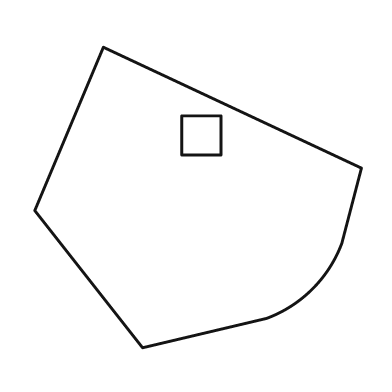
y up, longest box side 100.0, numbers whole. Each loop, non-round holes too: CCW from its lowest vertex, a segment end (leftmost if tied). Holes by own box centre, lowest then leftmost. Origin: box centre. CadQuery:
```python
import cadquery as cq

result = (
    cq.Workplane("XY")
    .moveTo(-17.0, -46.0)
    .lineTo(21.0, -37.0)
    .threePointArc((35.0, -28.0), (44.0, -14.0))
    .lineTo(50.0, 9.0)
    .lineTo(-29.0, 46.0)
    .lineTo(-50.0, -4.0)
    .close()
    .moveTo(-5.0, 13.0)
    .lineTo(7.0, 13.0)
    .lineTo(7.0, 25.0)
    .lineTo(-5.0, 25.0)
    .close()
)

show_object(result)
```